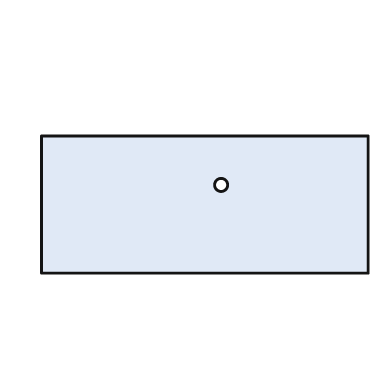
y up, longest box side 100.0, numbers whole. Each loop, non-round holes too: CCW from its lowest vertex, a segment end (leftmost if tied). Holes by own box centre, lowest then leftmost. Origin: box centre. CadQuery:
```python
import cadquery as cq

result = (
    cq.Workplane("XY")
    .moveTo(-50.0, -21.0)
    .lineTo(50.0, -21.0)
    .lineTo(50.0, 21.0)
    .lineTo(-50.0, 21.0)
    .close()
    .moveTo(5.0, 6.0)
    .circle(2.0)
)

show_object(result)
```